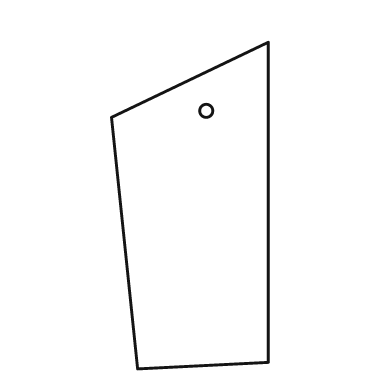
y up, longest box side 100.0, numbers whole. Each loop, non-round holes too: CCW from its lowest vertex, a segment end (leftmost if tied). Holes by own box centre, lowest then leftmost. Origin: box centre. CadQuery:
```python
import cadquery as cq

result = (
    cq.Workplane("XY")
    .moveTo(-16.0, -50.0)
    .lineTo(24.0, -48.0)
    .lineTo(24.0, 50.0)
    .lineTo(-24.0, 27.0)
    .close()
    .moveTo(5.0, 29.0)
    .circle(2.0)
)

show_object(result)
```